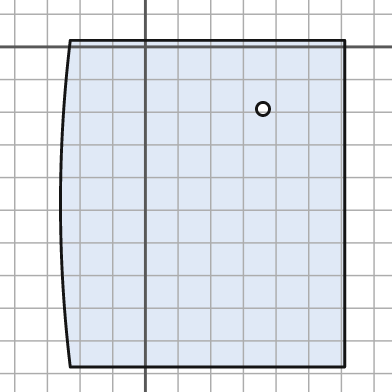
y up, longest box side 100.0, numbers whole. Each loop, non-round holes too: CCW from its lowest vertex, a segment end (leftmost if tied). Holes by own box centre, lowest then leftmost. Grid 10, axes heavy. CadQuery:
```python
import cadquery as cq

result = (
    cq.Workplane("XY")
    .moveTo(-23.0, -98.0)
    .lineTo(61.0, -98.0)
    .lineTo(61.0, 2.0)
    .lineTo(-23.0, 2.0)
    .threePointArc((-26.0, -48.0), (-23.0, -98.0))
    .close()
    .moveTo(36.0, -19.0)
    .circle(2.0)
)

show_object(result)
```